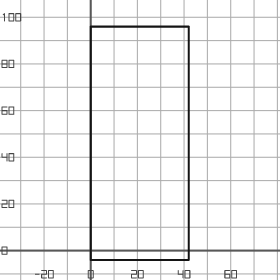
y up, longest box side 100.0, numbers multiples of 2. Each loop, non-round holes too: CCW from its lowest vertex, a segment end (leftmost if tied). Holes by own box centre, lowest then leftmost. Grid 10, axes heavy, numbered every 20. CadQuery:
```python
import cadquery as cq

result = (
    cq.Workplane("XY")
    .moveTo(0.0, -4.0)
    .lineTo(42.0, -4.0)
    .lineTo(42.0, 96.0)
    .lineTo(0.0, 96.0)
    .close()
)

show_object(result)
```